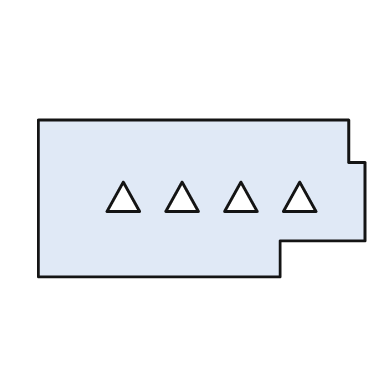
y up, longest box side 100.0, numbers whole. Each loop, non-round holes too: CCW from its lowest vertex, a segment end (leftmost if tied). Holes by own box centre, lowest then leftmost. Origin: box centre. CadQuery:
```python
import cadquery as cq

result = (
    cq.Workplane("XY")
    .moveTo(-50.0, -24.0)
    .lineTo(24.0, -24.0)
    .lineTo(24.0, -13.0)
    .lineTo(50.0, -13.0)
    .lineTo(50.0, 11.0)
    .lineTo(45.0, 11.0)
    .lineTo(45.0, 24.0)
    .lineTo(-50.0, 24.0)
    .close()
    .moveTo(-29.0, -4.0)
    .lineTo(-19.0, -4.0)
    .lineTo(-24.0, 5.0)
    .close()
    .moveTo(-11.0, -4.0)
    .lineTo(-1.0, -4.0)
    .lineTo(-6.0, 5.0)
    .close()
    .moveTo(7.0, -4.0)
    .lineTo(17.0, -4.0)
    .lineTo(12.0, 5.0)
    .close()
    .moveTo(25.0, -4.0)
    .lineTo(35.0, -4.0)
    .lineTo(30.0, 5.0)
    .close()
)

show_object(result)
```